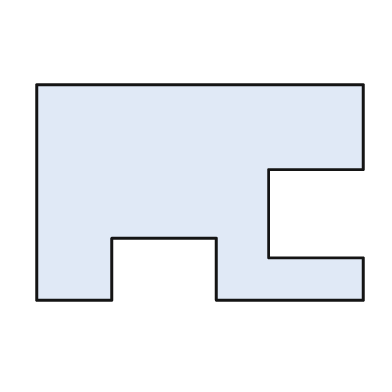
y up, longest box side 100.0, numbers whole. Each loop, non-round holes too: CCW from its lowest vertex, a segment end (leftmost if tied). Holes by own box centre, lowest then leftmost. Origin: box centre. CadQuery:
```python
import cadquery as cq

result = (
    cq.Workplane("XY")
    .moveTo(-50.0, -33.0)
    .lineTo(-27.0, -33.0)
    .lineTo(-27.0, -14.0)
    .lineTo(5.0, -14.0)
    .lineTo(5.0, -33.0)
    .lineTo(50.0, -33.0)
    .lineTo(50.0, -20.0)
    .lineTo(21.0, -20.0)
    .lineTo(21.0, 7.0)
    .lineTo(50.0, 7.0)
    .lineTo(50.0, 33.0)
    .lineTo(-50.0, 33.0)
    .close()
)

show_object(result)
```